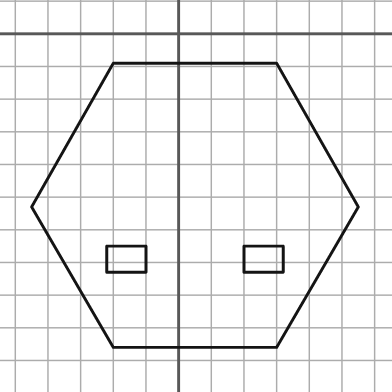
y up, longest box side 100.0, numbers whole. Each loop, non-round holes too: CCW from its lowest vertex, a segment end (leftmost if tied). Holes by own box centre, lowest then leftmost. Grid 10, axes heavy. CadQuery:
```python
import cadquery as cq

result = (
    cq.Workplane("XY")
    .moveTo(-20.0, -96.0)
    .lineTo(30.0, -96.0)
    .lineTo(55.0, -53.0)
    .lineTo(30.0, -9.0)
    .lineTo(-20.0, -9.0)
    .lineTo(-45.0, -53.0)
    .close()
    .moveTo(-22.0, -73.0)
    .lineTo(-10.0, -73.0)
    .lineTo(-10.0, -65.0)
    .lineTo(-22.0, -65.0)
    .close()
    .moveTo(20.0, -73.0)
    .lineTo(32.0, -73.0)
    .lineTo(32.0, -65.0)
    .lineTo(20.0, -65.0)
    .close()
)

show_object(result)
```